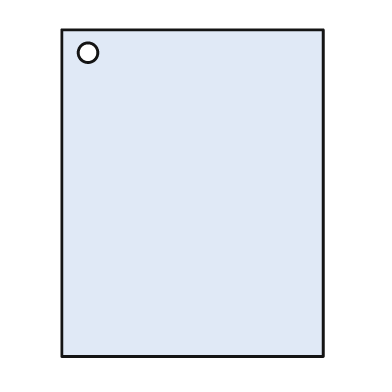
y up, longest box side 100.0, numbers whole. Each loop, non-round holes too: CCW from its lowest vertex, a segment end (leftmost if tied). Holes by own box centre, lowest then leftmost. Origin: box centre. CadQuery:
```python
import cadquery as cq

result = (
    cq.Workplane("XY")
    .moveTo(-40.0, -50.0)
    .lineTo(40.0, -50.0)
    .lineTo(40.0, 50.0)
    .lineTo(-40.0, 50.0)
    .close()
    .moveTo(-32.0, 43.0)
    .circle(3.0)
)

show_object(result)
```